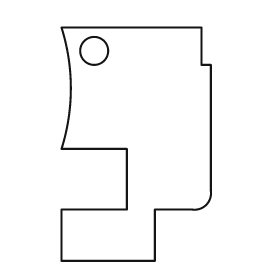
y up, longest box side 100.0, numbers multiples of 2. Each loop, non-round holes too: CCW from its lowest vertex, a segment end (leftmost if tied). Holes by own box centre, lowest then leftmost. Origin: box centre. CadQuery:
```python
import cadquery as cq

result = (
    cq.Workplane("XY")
    .moveTo(-32.0, -50.0)
    .lineTo(8.0, -50.0)
    .lineTo(8.0, -28.0)
    .lineTo(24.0, -28.0)
    .threePointArc((30.0, -26.0), (32.0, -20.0))
    .lineTo(32.0, 34.0)
    .lineTo(28.0, 34.0)
    .lineTo(28.0, 50.0)
    .lineTo(-32.0, 50.0)
    .threePointArc((-28.0, 24.0), (-32.0, -2.0))
    .lineTo(-4.0, -2.0)
    .lineTo(-4.0, -28.0)
    .lineTo(-32.0, -28.0)
    .close()
    .moveTo(-18.0, 40.0)
    .circle(6.0)
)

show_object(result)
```